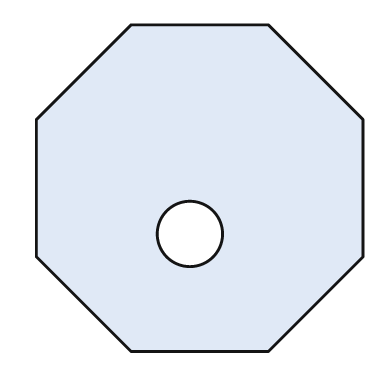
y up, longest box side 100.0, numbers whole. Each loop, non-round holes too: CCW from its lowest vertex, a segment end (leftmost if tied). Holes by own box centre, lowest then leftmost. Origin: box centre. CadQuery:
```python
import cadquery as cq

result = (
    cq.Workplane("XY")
    .moveTo(-21.0, -50.0)
    .lineTo(21.0, -50.0)
    .lineTo(50.0, -21.0)
    .lineTo(50.0, 21.0)
    .lineTo(21.0, 50.0)
    .lineTo(-21.0, 50.0)
    .lineTo(-50.0, 21.0)
    .lineTo(-50.0, -21.0)
    .close()
    .moveTo(-3.0, -14.0)
    .circle(10.0)
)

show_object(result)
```